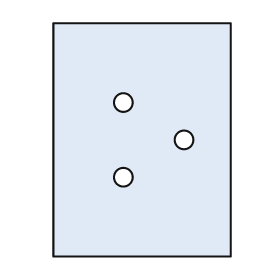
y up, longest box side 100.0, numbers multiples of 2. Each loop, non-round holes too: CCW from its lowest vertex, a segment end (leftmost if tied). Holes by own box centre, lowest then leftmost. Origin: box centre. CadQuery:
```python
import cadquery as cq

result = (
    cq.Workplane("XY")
    .moveTo(-38.0, -50.0)
    .lineTo(38.0, -50.0)
    .lineTo(38.0, 50.0)
    .lineTo(-38.0, 50.0)
    .close()
    .moveTo(-8.0, -16.0)
    .circle(4.0)
    .moveTo(18.0, 0.0)
    .circle(4.0)
    .moveTo(-8.0, 16.0)
    .circle(4.0)
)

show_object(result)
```